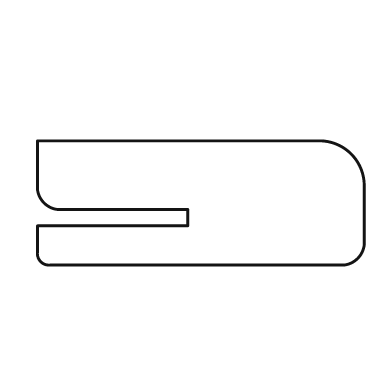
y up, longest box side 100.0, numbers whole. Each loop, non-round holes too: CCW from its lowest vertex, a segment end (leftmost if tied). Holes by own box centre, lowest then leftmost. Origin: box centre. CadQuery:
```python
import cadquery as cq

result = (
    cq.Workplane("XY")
    .moveTo(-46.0, -19.0)
    .lineTo(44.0, -19.0)
    .threePointArc((48.0, -17.0), (50.0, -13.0))
    .lineTo(50.0, 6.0)
    .threePointArc((46.0, 15.0), (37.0, 19.0))
    .lineTo(-50.0, 19.0)
    .lineTo(-50.0, 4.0)
    .threePointArc((-48.0, 0.0), (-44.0, -2.0))
    .lineTo(-4.0, -2.0)
    .lineTo(-4.0, -7.0)
    .lineTo(-50.0, -7.0)
    .lineTo(-50.0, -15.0)
    .threePointArc((-49.0, -18.0), (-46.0, -19.0))
    .close()
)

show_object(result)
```